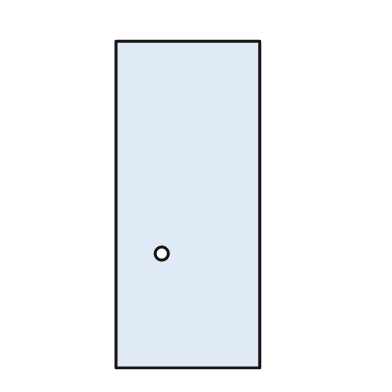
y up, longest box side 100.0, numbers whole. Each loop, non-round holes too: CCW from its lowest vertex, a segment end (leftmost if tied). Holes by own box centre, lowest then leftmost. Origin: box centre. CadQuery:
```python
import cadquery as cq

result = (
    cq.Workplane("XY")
    .moveTo(-22.0, -50.0)
    .lineTo(22.0, -50.0)
    .lineTo(22.0, 50.0)
    .lineTo(-22.0, 50.0)
    .close()
    .moveTo(-8.0, -15.0)
    .circle(2.0)
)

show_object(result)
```